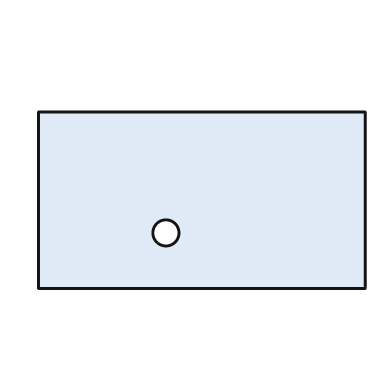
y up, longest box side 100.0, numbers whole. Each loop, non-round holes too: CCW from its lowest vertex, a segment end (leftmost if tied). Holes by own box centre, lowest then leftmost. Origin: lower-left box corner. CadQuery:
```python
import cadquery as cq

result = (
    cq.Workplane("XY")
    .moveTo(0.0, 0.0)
    .lineTo(100.0, 0.0)
    .lineTo(100.0, 54.0)
    .lineTo(0.0, 54.0)
    .close()
    .moveTo(39.0, 17.0)
    .circle(4.0)
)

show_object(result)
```